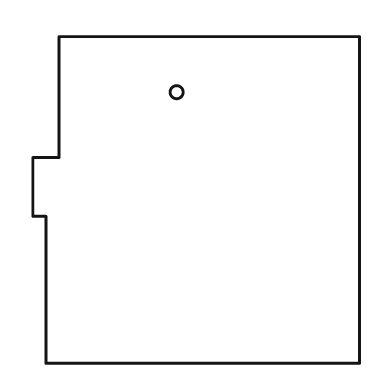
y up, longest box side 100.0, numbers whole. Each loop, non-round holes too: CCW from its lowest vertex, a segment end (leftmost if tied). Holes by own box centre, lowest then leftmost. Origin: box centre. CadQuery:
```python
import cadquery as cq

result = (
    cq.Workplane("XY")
    .moveTo(-46.0, -50.0)
    .lineTo(50.0, -50.0)
    .lineTo(50.0, 50.0)
    .lineTo(-42.0, 50.0)
    .lineTo(-42.0, 13.0)
    .lineTo(-50.0, 13.0)
    .lineTo(-50.0, -5.0)
    .lineTo(-46.0, -5.0)
    .close()
    .moveTo(-6.0, 33.0)
    .circle(2.0)
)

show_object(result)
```